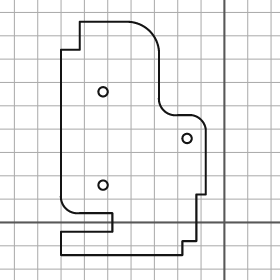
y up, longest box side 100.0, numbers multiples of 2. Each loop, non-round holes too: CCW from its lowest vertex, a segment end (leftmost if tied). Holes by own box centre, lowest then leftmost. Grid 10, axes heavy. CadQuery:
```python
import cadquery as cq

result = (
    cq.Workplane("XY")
    .moveTo(-70.0, -14.0)
    .lineTo(-18.0, -14.0)
    .lineTo(-18.0, -8.0)
    .lineTo(-12.0, -8.0)
    .lineTo(-12.0, 12.0)
    .lineTo(-8.0, 12.0)
    .lineTo(-8.0, 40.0)
    .threePointArc((-10.0, 44.0), (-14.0, 46.0))
    .lineTo(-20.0, 46.0)
    .threePointArc((-26.0, 48.0), (-28.0, 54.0))
    .lineTo(-28.0, 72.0)
    .threePointArc((-32.0, 82.0), (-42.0, 86.0))
    .lineTo(-62.0, 86.0)
    .lineTo(-62.0, 74.0)
    .lineTo(-70.0, 74.0)
    .lineTo(-70.0, 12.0)
    .threePointArc((-68.0, 6.0), (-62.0, 4.0))
    .lineTo(-48.0, 4.0)
    .lineTo(-48.0, -4.0)
    .lineTo(-70.0, -4.0)
    .close()
    .moveTo(-52.0, 16.0)
    .circle(2.0)
    .moveTo(-16.0, 36.0)
    .circle(2.0)
    .moveTo(-52.0, 56.0)
    .circle(2.0)
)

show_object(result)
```